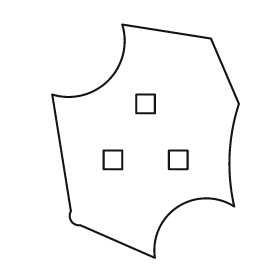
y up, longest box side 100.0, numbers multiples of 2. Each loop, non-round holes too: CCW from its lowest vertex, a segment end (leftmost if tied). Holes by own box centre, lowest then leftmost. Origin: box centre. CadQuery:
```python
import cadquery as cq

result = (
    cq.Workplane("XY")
    .moveTo(4.0, -50.0)
    .threePointArc((14.0, -28.0), (38.0, -28.0))
    .threePointArc((36.0, -6.0), (40.0, 16.0))
    .lineTo(28.0, 44.0)
    .lineTo(-10.0, 50.0)
    .threePointArc((-16.0, 26.0), (-40.0, 20.0))
    .lineTo(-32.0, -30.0)
    .threePointArc((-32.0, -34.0), (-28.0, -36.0))
    .close()
    .moveTo(-18.0, -12.0)
    .lineTo(-10.0, -12.0)
    .lineTo(-10.0, -4.0)
    .lineTo(-18.0, -4.0)
    .close()
    .moveTo(10.0, -12.0)
    .lineTo(18.0, -12.0)
    .lineTo(18.0, -4.0)
    .lineTo(10.0, -4.0)
    .close()
    .moveTo(-4.0, 12.0)
    .lineTo(4.0, 12.0)
    .lineTo(4.0, 20.0)
    .lineTo(-4.0, 20.0)
    .close()
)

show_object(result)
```